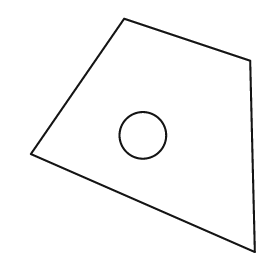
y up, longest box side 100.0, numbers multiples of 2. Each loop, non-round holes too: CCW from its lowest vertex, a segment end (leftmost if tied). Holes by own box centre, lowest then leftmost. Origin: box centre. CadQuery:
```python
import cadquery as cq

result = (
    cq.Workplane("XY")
    .moveTo(48.0, -50.0)
    .lineTo(46.0, 32.0)
    .lineTo(-8.0, 50.0)
    .lineTo(-48.0, -8.0)
    .close()
    .moveTo(0.0, 0.0)
    .circle(10.0)
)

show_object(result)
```